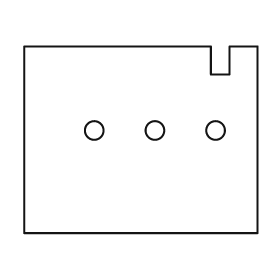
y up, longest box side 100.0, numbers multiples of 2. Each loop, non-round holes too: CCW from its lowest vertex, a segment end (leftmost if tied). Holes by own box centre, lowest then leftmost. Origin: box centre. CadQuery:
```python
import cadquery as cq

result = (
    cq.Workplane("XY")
    .moveTo(-50.0, -40.0)
    .lineTo(50.0, -40.0)
    .lineTo(50.0, 40.0)
    .lineTo(38.0, 40.0)
    .lineTo(38.0, 28.0)
    .lineTo(30.0, 28.0)
    .lineTo(30.0, 40.0)
    .lineTo(-50.0, 40.0)
    .close()
    .moveTo(-20.0, 4.0)
    .circle(4.0)
    .moveTo(6.0, 4.0)
    .circle(4.0)
    .moveTo(32.0, 4.0)
    .circle(4.0)
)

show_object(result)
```